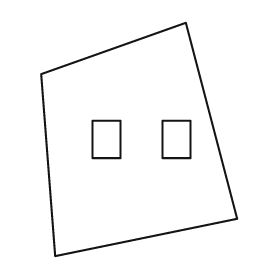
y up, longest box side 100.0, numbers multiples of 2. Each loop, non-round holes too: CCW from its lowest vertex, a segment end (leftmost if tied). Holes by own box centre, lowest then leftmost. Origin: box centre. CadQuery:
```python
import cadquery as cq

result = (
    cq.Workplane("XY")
    .moveTo(-36.0, -50.0)
    .lineTo(42.0, -34.0)
    .lineTo(20.0, 50.0)
    .lineTo(-42.0, 28.0)
    .close()
    .moveTo(-20.0, -8.0)
    .lineTo(-8.0, -8.0)
    .lineTo(-8.0, 8.0)
    .lineTo(-20.0, 8.0)
    .close()
    .moveTo(10.0, -8.0)
    .lineTo(22.0, -8.0)
    .lineTo(22.0, 8.0)
    .lineTo(10.0, 8.0)
    .close()
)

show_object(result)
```